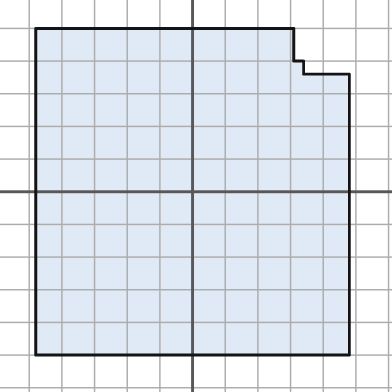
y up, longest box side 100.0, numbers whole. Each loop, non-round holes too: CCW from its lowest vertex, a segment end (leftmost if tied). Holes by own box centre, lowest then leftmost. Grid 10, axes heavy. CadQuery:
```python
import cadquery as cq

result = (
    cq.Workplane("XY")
    .moveTo(-48.0, -50.0)
    .lineTo(48.0, -50.0)
    .lineTo(48.0, 36.0)
    .lineTo(34.0, 36.0)
    .lineTo(34.0, 40.0)
    .lineTo(31.0, 40.0)
    .lineTo(31.0, 50.0)
    .lineTo(-48.0, 50.0)
    .close()
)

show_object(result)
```